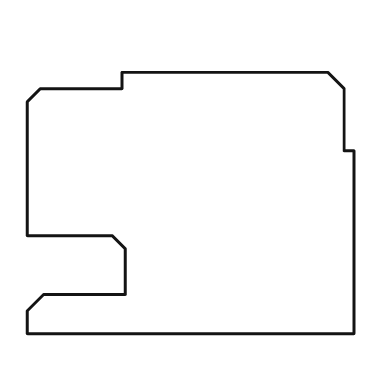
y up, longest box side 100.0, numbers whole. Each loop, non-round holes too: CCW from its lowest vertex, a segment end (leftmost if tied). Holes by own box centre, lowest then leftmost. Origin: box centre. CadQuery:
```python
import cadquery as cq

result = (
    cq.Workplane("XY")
    .moveTo(-50.0, -40.0)
    .lineTo(50.0, -40.0)
    .lineTo(50.0, 16.0)
    .lineTo(47.0, 16.0)
    .lineTo(47.0, 35.0)
    .lineTo(42.0, 40.0)
    .lineTo(-21.0, 40.0)
    .lineTo(-21.0, 35.0)
    .lineTo(-46.0, 35.0)
    .lineTo(-50.0, 31.0)
    .lineTo(-50.0, -10.0)
    .lineTo(-24.0, -10.0)
    .lineTo(-20.0, -14.0)
    .lineTo(-20.0, -28.0)
    .lineTo(-45.0, -28.0)
    .lineTo(-50.0, -33.0)
    .close()
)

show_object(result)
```